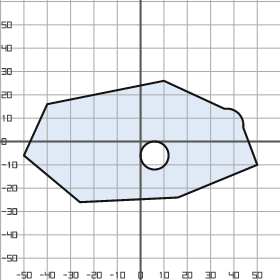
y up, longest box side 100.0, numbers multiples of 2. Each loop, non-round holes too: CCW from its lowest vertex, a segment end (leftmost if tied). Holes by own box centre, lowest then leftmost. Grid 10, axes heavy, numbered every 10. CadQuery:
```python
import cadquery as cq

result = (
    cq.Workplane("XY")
    .moveTo(-26.0, -26.0)
    .lineTo(16.0, -24.0)
    .lineTo(50.0, -10.0)
    .lineTo(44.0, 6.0)
    .threePointArc((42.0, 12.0), (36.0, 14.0))
    .lineTo(10.0, 26.0)
    .lineTo(-40.0, 16.0)
    .lineTo(-50.0, -6.0)
    .close()
    .moveTo(6.0, -6.0)
    .circle(6.0)
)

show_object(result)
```